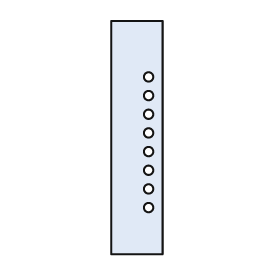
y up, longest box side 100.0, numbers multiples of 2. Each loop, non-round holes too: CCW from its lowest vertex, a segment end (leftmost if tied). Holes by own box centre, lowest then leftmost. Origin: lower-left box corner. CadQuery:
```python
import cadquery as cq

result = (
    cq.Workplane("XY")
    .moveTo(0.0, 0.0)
    .lineTo(22.0, 0.0)
    .lineTo(22.0, 100.0)
    .lineTo(0.0, 100.0)
    .close()
    .moveTo(16.0, 20.0)
    .circle(2.0)
    .moveTo(16.0, 28.0)
    .circle(2.0)
    .moveTo(16.0, 36.0)
    .circle(2.0)
    .moveTo(16.0, 44.0)
    .circle(2.0)
    .moveTo(16.0, 52.0)
    .circle(2.0)
    .moveTo(16.0, 60.0)
    .circle(2.0)
    .moveTo(16.0, 68.0)
    .circle(2.0)
    .moveTo(16.0, 76.0)
    .circle(2.0)
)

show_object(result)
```